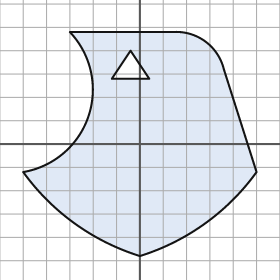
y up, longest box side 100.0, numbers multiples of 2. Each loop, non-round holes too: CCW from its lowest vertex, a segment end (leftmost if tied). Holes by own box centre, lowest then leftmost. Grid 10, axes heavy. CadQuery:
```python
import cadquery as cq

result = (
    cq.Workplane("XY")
    .moveTo(0.0, -48.0)
    .threePointArc((28.0, -34.0), (50.0, -12.0))
    .lineTo(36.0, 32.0)
    .threePointArc((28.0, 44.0), (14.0, 48.0))
    .lineTo(-30.0, 48.0)
    .threePointArc((-22.0, 12.0), (-50.0, -12.0))
    .threePointArc((-28.0, -34.0), (0.0, -48.0))
    .close()
    .moveTo(-12.0, 28.0)
    .lineTo(4.0, 28.0)
    .lineTo(-4.0, 40.0)
    .close()
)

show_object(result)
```